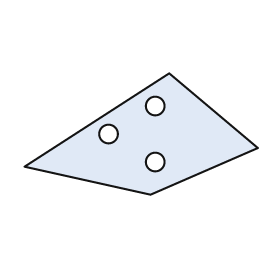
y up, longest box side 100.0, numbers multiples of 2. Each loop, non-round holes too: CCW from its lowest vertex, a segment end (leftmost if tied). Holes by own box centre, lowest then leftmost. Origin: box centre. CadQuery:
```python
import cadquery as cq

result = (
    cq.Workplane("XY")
    .moveTo(4.0, -26.0)
    .lineTo(50.0, -6.0)
    .lineTo(12.0, 26.0)
    .lineTo(-50.0, -14.0)
    .close()
    .moveTo(6.0, -12.0)
    .circle(4.0)
    .moveTo(-14.0, 0.0)
    .circle(4.0)
    .moveTo(6.0, 12.0)
    .circle(4.0)
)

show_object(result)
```